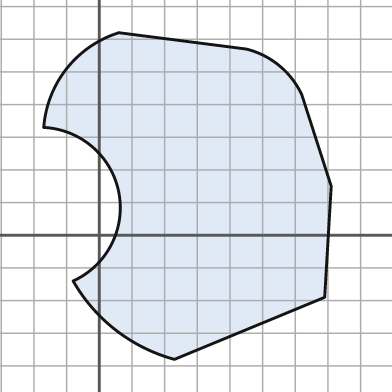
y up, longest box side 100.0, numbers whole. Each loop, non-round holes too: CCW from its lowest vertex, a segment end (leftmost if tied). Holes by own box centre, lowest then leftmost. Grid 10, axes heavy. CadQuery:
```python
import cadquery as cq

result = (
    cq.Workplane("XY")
    .moveTo(23.0, -38.0)
    .lineTo(69.0, -19.0)
    .lineTo(71.0, 15.0)
    .lineTo(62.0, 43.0)
    .threePointArc((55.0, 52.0), (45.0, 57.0))
    .lineTo(6.0, 62.0)
    .threePointArc((-10.0, 51.0), (-17.0, 33.0))
    .threePointArc((6.0, 13.0), (-8.0, -14.0))
    .threePointArc((5.0, -29.0), (23.0, -38.0))
    .close()
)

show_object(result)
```